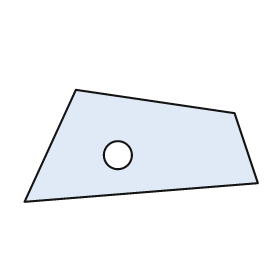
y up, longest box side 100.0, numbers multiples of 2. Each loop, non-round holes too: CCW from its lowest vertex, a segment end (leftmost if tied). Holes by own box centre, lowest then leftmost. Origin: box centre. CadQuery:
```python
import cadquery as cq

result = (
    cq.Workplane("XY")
    .moveTo(-50.0, -24.0)
    .lineTo(50.0, -16.0)
    .lineTo(40.0, 14.0)
    .lineTo(-28.0, 24.0)
    .close()
    .moveTo(-10.0, -4.0)
    .circle(6.0)
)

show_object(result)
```